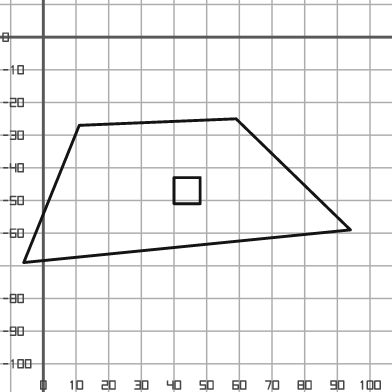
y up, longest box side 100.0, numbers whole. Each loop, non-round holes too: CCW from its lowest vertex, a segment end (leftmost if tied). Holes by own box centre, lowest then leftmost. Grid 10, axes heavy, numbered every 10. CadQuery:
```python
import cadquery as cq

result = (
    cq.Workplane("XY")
    .moveTo(-6.0, -69.0)
    .lineTo(94.0, -59.0)
    .lineTo(59.0, -25.0)
    .lineTo(11.0, -27.0)
    .close()
    .moveTo(40.0, -51.0)
    .lineTo(48.0, -51.0)
    .lineTo(48.0, -43.0)
    .lineTo(40.0, -43.0)
    .close()
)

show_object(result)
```